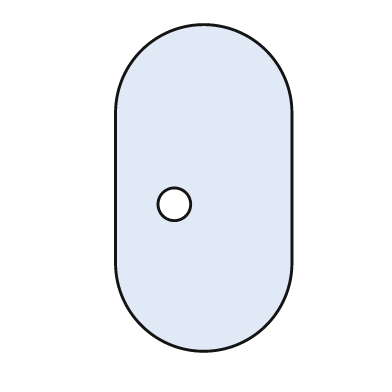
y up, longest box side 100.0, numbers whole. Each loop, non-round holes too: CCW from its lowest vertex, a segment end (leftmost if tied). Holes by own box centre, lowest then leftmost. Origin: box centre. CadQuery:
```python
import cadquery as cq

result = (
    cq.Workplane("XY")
    .moveTo(-27.0, -23.0)
    .threePointArc((0.0, -50.0), (27.0, -23.0))
    .lineTo(27.0, 23.0)
    .threePointArc((0.0, 50.0), (-27.0, 23.0))
    .close()
    .moveTo(-9.0, -5.0)
    .circle(5.0)
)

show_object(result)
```